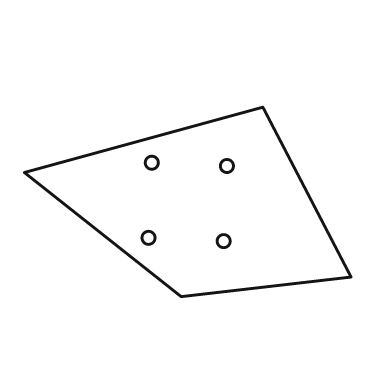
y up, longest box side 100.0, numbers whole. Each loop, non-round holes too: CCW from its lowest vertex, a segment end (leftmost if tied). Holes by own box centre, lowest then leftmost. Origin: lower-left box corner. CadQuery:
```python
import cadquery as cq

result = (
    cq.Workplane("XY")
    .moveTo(48.0, 0.0)
    .lineTo(100.0, 6.0)
    .lineTo(73.0, 58.0)
    .lineTo(0.0, 38.0)
    .close()
    .moveTo(61.0, 17.0)
    .circle(2.0)
    .moveTo(38.0, 18.0)
    .circle(2.0)
    .moveTo(62.0, 40.0)
    .circle(2.0)
    .moveTo(39.0, 41.0)
    .circle(2.0)
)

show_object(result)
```